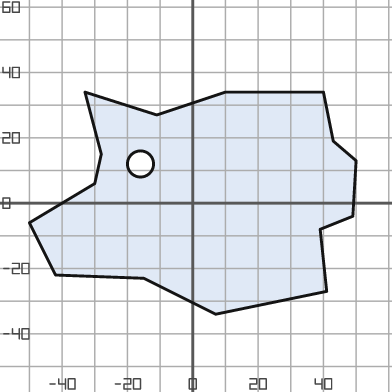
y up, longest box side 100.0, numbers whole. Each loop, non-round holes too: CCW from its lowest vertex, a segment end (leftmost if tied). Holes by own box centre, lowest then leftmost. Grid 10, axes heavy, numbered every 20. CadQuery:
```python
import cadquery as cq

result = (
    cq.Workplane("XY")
    .moveTo(7.0, -34.0)
    .lineTo(41.0, -27.0)
    .lineTo(39.0, -8.0)
    .lineTo(49.0, -4.0)
    .lineTo(50.0, 13.0)
    .lineTo(43.0, 19.0)
    .lineTo(40.0, 34.0)
    .lineTo(10.0, 34.0)
    .lineTo(-11.0, 27.0)
    .lineTo(-33.0, 34.0)
    .lineTo(-28.0, 15.0)
    .lineTo(-30.0, 6.0)
    .lineTo(-50.0, -6.0)
    .lineTo(-42.0, -22.0)
    .lineTo(-15.0, -23.0)
    .close()
    .moveTo(-16.0, 12.0)
    .circle(4.0)
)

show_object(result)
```